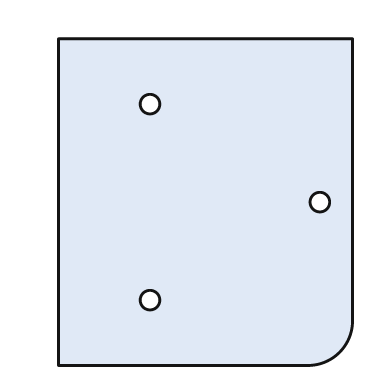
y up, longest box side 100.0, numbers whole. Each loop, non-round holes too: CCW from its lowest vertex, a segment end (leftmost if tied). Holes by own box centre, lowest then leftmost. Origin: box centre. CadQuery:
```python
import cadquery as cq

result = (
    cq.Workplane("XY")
    .moveTo(-45.0, -50.0)
    .lineTo(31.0, -50.0)
    .threePointArc((41.0, -46.0), (45.0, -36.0))
    .lineTo(45.0, 50.0)
    .lineTo(-45.0, 50.0)
    .close()
    .moveTo(-17.0, -30.0)
    .circle(3.0)
    .moveTo(35.0, 0.0)
    .circle(3.0)
    .moveTo(-17.0, 30.0)
    .circle(3.0)
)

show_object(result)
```